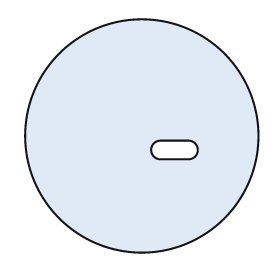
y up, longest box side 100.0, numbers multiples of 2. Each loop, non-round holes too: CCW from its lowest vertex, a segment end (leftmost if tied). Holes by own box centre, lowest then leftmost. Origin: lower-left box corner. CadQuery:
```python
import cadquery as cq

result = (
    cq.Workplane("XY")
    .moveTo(50.0, 50.0)
    .circle(50.0)
    .moveTo(58.0, 40.0)
    .lineTo(70.0, 40.0)
    .threePointArc((74.0, 44.0), (70.0, 48.0))
    .lineTo(58.0, 48.0)
    .threePointArc((54.0, 44.0), (58.0, 40.0))
    .close()
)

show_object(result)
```